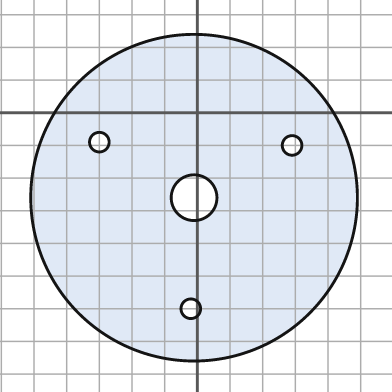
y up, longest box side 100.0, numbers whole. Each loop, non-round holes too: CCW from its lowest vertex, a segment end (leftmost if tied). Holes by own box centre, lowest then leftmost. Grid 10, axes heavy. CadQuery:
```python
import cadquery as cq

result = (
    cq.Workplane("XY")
    .moveTo(-1.0, -26.0)
    .circle(50.0)
    .moveTo(-2.0, -60.0)
    .circle(3.0)
    .moveTo(-1.0, -26.0)
    .circle(7.0)
    .moveTo(29.0, -10.0)
    .circle(3.0)
    .moveTo(-30.0, -9.0)
    .circle(3.0)
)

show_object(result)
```